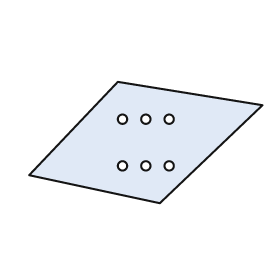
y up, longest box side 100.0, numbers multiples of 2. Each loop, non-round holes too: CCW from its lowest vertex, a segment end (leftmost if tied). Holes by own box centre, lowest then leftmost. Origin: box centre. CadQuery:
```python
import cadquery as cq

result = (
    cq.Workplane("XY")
    .moveTo(6.0, -26.0)
    .lineTo(50.0, 16.0)
    .lineTo(-12.0, 26.0)
    .lineTo(-50.0, -14.0)
    .close()
    .moveTo(-10.0, -10.0)
    .circle(2.0)
    .moveTo(0.0, -10.0)
    .circle(2.0)
    .moveTo(10.0, -10.0)
    .circle(2.0)
    .moveTo(-10.0, 10.0)
    .circle(2.0)
    .moveTo(0.0, 10.0)
    .circle(2.0)
    .moveTo(10.0, 10.0)
    .circle(2.0)
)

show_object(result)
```